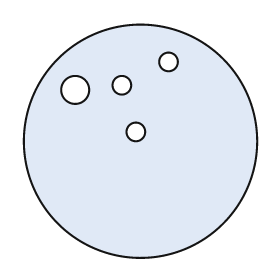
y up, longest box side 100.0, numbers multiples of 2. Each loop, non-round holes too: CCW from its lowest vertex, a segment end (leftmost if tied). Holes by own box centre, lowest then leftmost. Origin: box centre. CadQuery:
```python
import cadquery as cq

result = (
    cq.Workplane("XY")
    .moveTo(0.0, 0.0)
    .circle(50.0)
    .moveTo(-2.0, 4.0)
    .circle(4.0)
    .moveTo(-28.0, 22.0)
    .circle(6.0)
    .moveTo(-8.0, 24.0)
    .circle(4.0)
    .moveTo(12.0, 34.0)
    .circle(4.0)
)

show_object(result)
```